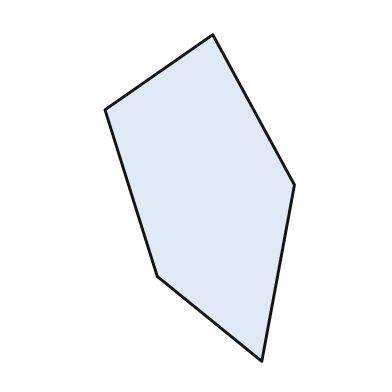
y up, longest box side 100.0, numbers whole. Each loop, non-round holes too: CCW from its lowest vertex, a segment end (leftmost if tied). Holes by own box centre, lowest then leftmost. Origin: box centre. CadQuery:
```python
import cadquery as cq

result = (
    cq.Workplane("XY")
    .moveTo(19.0, -50.0)
    .lineTo(29.0, 4.0)
    .lineTo(4.0, 50.0)
    .lineTo(-29.0, 27.0)
    .lineTo(-13.0, -24.0)
    .close()
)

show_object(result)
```